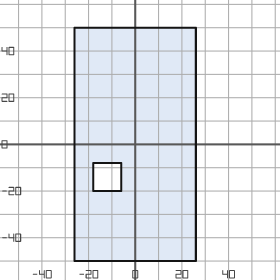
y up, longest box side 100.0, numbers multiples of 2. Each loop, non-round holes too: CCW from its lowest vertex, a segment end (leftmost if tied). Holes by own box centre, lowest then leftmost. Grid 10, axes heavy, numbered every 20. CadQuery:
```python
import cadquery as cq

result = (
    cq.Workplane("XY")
    .moveTo(-26.0, -50.0)
    .lineTo(26.0, -50.0)
    .lineTo(26.0, 50.0)
    .lineTo(-26.0, 50.0)
    .close()
    .moveTo(-18.0, -20.0)
    .lineTo(-6.0, -20.0)
    .lineTo(-6.0, -8.0)
    .lineTo(-18.0, -8.0)
    .close()
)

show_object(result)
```